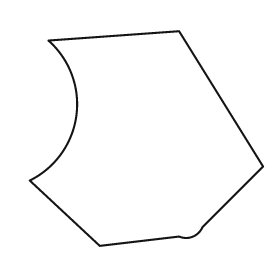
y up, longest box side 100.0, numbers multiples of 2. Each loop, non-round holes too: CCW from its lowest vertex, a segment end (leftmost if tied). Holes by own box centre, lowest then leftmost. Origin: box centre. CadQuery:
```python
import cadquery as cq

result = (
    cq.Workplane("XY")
    .moveTo(-20.0, -46.0)
    .lineTo(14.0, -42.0)
    .threePointArc((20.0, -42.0), (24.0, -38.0))
    .lineTo(50.0, -12.0)
    .lineTo(14.0, 46.0)
    .lineTo(-42.0, 42.0)
    .threePointArc((-30.0, 10.0), (-50.0, -18.0))
    .close()
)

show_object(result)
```